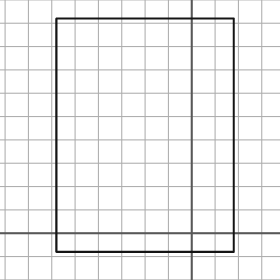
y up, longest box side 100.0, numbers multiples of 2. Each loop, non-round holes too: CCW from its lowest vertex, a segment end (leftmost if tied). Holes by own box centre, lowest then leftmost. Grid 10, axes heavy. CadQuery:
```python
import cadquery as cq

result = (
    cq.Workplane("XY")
    .moveTo(-58.0, -8.0)
    .lineTo(18.0, -8.0)
    .lineTo(18.0, 92.0)
    .lineTo(-58.0, 92.0)
    .close()
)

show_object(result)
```